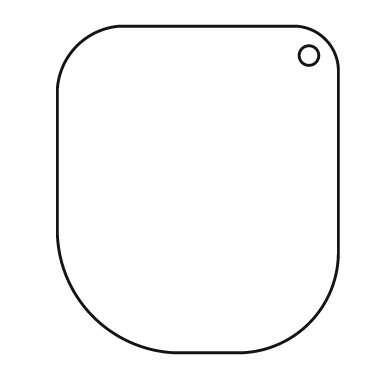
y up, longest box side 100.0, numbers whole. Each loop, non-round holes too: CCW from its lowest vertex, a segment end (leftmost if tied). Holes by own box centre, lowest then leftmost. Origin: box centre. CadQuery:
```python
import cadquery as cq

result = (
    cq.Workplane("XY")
    .moveTo(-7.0, -50.0)
    .lineTo(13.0, -50.0)
    .threePointArc((34.0, -41.0), (43.0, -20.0))
    .lineTo(43.0, 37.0)
    .threePointArc((39.0, 46.0), (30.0, 50.0))
    .lineTo(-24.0, 50.0)
    .threePointArc((-37.0, 44.0), (-43.0, 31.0))
    .lineTo(-43.0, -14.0)
    .threePointArc((-32.0, -39.0), (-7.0, -50.0))
    .close()
    .moveTo(34.0, 41.0)
    .circle(3.0)
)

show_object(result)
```